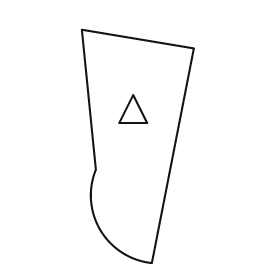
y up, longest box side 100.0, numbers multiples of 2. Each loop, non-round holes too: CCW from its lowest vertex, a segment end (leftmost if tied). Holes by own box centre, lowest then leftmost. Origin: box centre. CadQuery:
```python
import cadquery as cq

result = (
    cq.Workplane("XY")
    .moveTo(6.0, -50.0)
    .lineTo(24.0, 42.0)
    .lineTo(-24.0, 50.0)
    .lineTo(-18.0, -10.0)
    .threePointArc((-16.0, -36.0), (6.0, -50.0))
    .close()
    .moveTo(-8.0, 10.0)
    .lineTo(4.0, 10.0)
    .lineTo(-2.0, 22.0)
    .close()
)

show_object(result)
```